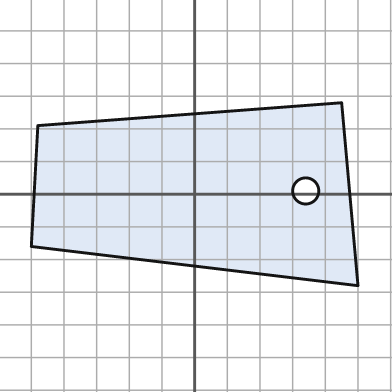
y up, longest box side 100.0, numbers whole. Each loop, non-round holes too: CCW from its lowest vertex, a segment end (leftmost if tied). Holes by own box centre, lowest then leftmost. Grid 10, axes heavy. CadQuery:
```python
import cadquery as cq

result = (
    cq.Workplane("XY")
    .moveTo(50.0, -28.0)
    .lineTo(45.0, 28.0)
    .lineTo(-48.0, 21.0)
    .lineTo(-50.0, -16.0)
    .close()
    .moveTo(34.0, 1.0)
    .circle(4.0)
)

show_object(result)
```